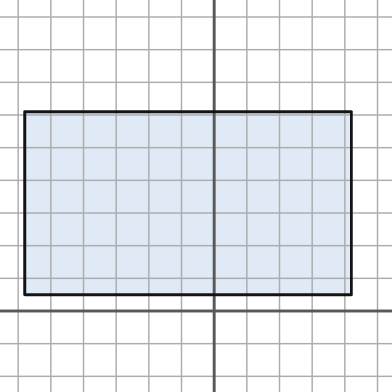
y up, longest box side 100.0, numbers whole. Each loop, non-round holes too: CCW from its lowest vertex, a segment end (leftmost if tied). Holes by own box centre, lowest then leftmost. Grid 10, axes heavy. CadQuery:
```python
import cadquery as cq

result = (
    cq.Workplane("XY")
    .moveTo(-58.0, 5.0)
    .lineTo(42.0, 5.0)
    .lineTo(42.0, 61.0)
    .lineTo(-58.0, 61.0)
    .close()
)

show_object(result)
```